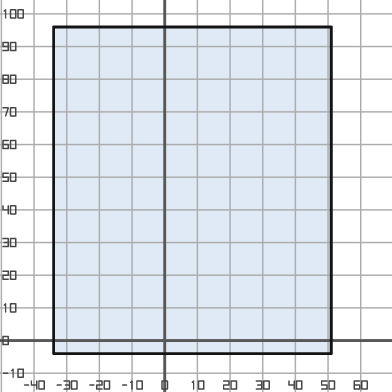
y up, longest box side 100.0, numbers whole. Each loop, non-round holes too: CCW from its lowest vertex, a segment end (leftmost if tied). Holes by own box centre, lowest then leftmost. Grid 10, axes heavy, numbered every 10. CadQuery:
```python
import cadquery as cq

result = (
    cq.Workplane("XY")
    .moveTo(-34.0, -4.0)
    .lineTo(51.0, -4.0)
    .lineTo(51.0, 96.0)
    .lineTo(-34.0, 96.0)
    .close()
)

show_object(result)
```